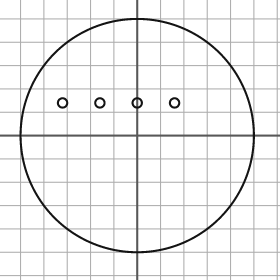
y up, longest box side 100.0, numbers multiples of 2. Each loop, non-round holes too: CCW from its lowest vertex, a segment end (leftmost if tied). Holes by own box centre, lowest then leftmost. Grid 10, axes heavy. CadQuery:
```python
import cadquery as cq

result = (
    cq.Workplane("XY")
    .moveTo(0.0, 0.0)
    .circle(50.0)
    .moveTo(-32.0, 14.0)
    .circle(2.0)
    .moveTo(-16.0, 14.0)
    .circle(2.0)
    .moveTo(0.0, 14.0)
    .circle(2.0)
    .moveTo(16.0, 14.0)
    .circle(2.0)
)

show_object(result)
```